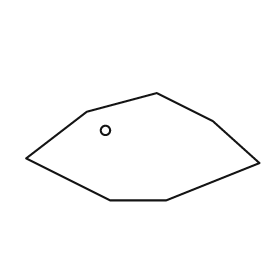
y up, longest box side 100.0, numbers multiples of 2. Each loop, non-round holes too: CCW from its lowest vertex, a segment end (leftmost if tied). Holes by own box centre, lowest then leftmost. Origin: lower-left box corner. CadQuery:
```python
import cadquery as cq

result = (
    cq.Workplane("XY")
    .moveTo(36.0, 0.0)
    .lineTo(60.0, 0.0)
    .lineTo(100.0, 16.0)
    .lineTo(80.0, 34.0)
    .lineTo(56.0, 46.0)
    .lineTo(26.0, 38.0)
    .lineTo(0.0, 18.0)
    .close()
    .moveTo(34.0, 30.0)
    .circle(2.0)
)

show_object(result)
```